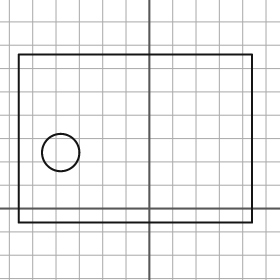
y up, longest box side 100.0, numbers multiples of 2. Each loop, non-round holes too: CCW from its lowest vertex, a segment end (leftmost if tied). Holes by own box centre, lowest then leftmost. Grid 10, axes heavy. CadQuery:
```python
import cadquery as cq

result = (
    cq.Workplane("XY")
    .moveTo(-56.0, -6.0)
    .lineTo(44.0, -6.0)
    .lineTo(44.0, 66.0)
    .lineTo(-56.0, 66.0)
    .close()
    .moveTo(-38.0, 24.0)
    .circle(8.0)
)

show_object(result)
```